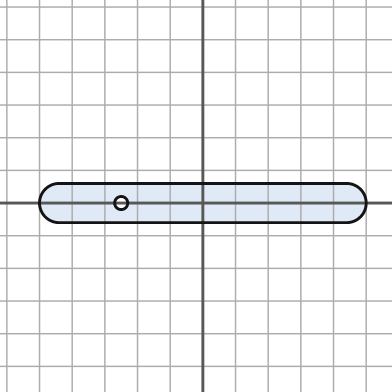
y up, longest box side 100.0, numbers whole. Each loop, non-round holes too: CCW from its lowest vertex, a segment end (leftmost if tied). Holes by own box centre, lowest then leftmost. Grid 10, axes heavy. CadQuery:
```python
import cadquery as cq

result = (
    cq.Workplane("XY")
    .moveTo(-44.0, -6.0)
    .lineTo(44.0, -6.0)
    .threePointArc((50.0, 0.0), (44.0, 6.0))
    .lineTo(-44.0, 6.0)
    .threePointArc((-50.0, 0.0), (-44.0, -6.0))
    .close()
    .moveTo(-25.0, 0.0)
    .circle(2.0)
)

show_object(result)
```